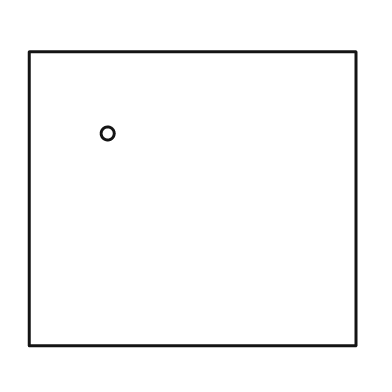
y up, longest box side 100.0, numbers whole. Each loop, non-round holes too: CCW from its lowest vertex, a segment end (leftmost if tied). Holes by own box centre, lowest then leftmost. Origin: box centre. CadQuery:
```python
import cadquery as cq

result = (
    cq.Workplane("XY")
    .moveTo(-50.0, -45.0)
    .lineTo(50.0, -45.0)
    .lineTo(50.0, 45.0)
    .lineTo(-50.0, 45.0)
    .close()
    .moveTo(-26.0, 20.0)
    .circle(2.0)
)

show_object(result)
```